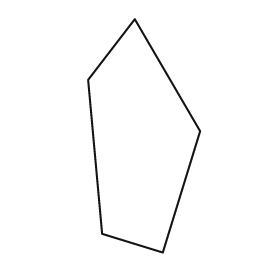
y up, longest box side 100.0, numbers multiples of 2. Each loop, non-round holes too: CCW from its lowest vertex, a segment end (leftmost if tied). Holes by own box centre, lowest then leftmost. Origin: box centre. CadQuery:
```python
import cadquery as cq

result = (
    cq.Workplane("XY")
    .moveTo(8.0, -50.0)
    .lineTo(24.0, 2.0)
    .lineTo(-4.0, 50.0)
    .lineTo(-24.0, 24.0)
    .lineTo(-18.0, -42.0)
    .close()
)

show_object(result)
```